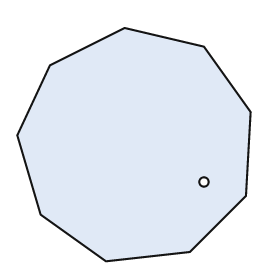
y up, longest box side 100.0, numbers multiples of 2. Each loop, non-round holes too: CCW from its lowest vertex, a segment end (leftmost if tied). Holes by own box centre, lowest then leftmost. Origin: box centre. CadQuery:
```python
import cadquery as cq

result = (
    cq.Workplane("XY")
    .moveTo(-12.0, -50.0)
    .lineTo(24.0, -46.0)
    .lineTo(48.0, -22.0)
    .lineTo(50.0, 14.0)
    .lineTo(30.0, 42.0)
    .lineTo(-4.0, 50.0)
    .lineTo(-36.0, 34.0)
    .lineTo(-50.0, 4.0)
    .lineTo(-40.0, -30.0)
    .close()
    .moveTo(30.0, -16.0)
    .circle(2.0)
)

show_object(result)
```